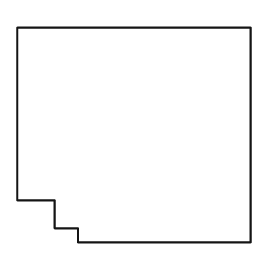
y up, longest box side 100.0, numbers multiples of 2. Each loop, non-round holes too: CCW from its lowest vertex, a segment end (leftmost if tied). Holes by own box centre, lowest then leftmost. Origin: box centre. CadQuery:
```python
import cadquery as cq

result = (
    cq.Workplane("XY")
    .moveTo(-24.0, -46.0)
    .lineTo(50.0, -46.0)
    .lineTo(50.0, 46.0)
    .lineTo(-50.0, 46.0)
    .lineTo(-50.0, -28.0)
    .lineTo(-34.0, -28.0)
    .lineTo(-34.0, -40.0)
    .lineTo(-24.0, -40.0)
    .close()
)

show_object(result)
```